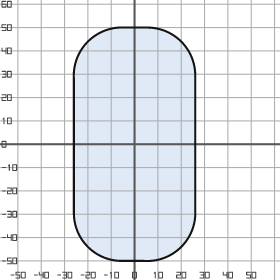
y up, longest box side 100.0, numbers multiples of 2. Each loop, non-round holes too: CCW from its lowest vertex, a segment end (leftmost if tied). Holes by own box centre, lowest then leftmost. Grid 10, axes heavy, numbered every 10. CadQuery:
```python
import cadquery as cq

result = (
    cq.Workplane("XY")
    .moveTo(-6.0, -50.0)
    .lineTo(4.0, -50.0)
    .threePointArc((20.0, -44.0), (26.0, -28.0))
    .lineTo(26.0, 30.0)
    .threePointArc((20.0, 44.0), (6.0, 50.0))
    .lineTo(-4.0, 50.0)
    .threePointArc((-20.0, 44.0), (-26.0, 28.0))
    .lineTo(-26.0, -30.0)
    .threePointArc((-20.0, -44.0), (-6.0, -50.0))
    .close()
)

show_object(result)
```